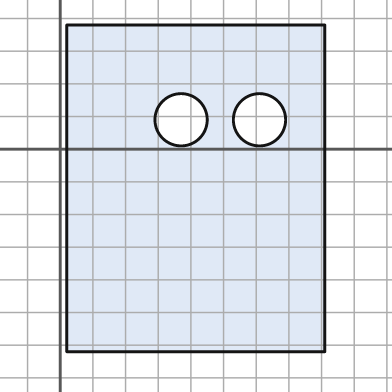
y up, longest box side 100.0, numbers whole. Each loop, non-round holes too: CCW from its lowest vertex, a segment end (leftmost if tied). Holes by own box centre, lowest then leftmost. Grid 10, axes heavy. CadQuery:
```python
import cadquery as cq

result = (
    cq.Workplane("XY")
    .moveTo(2.0, -62.0)
    .lineTo(81.0, -62.0)
    .lineTo(81.0, 38.0)
    .lineTo(2.0, 38.0)
    .close()
    .moveTo(37.0, 9.0)
    .circle(8.0)
    .moveTo(61.0, 9.0)
    .circle(8.0)
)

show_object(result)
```